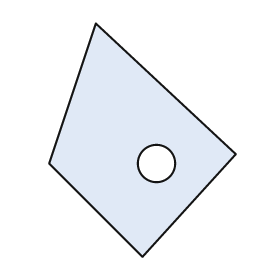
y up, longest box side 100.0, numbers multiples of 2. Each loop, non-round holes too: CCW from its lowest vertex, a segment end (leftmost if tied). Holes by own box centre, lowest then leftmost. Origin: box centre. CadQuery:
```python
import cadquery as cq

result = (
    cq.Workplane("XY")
    .moveTo(0.0, -50.0)
    .lineTo(40.0, -6.0)
    .lineTo(-20.0, 50.0)
    .lineTo(-40.0, -10.0)
    .close()
    .moveTo(6.0, -10.0)
    .circle(8.0)
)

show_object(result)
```